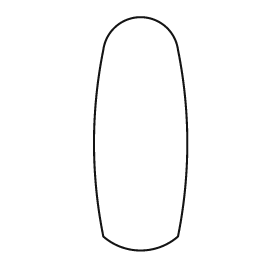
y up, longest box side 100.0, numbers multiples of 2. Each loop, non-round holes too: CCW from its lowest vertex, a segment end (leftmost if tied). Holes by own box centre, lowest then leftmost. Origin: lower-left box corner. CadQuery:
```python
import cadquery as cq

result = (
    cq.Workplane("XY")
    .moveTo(4.0, 6.0)
    .threePointArc((20.0, 0.0), (36.0, 6.0))
    .threePointArc((40.0, 46.0), (36.0, 86.0))
    .threePointArc((20.0, 100.0), (4.0, 86.0))
    .threePointArc((0.0, 46.0), (4.0, 6.0))
    .close()
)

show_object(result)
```